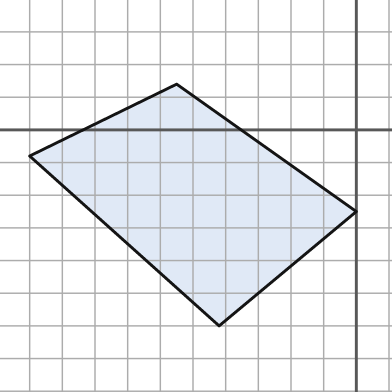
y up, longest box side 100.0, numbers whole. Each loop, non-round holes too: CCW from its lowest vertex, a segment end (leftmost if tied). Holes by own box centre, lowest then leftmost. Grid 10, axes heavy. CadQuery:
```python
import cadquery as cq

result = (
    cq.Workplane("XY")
    .moveTo(-42.0, -60.0)
    .lineTo(0.0, -25.0)
    .lineTo(-55.0, 14.0)
    .lineTo(-100.0, -8.0)
    .close()
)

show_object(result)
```